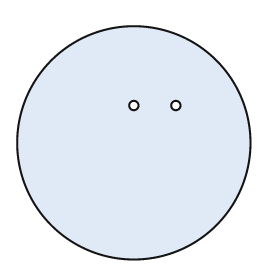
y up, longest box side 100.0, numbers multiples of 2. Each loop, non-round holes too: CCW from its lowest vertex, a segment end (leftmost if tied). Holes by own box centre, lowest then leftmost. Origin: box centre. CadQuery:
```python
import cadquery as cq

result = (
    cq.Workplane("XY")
    .moveTo(0.0, 0.0)
    .circle(50.0)
    .moveTo(0.0, 16.0)
    .circle(2.0)
    .moveTo(18.0, 16.0)
    .circle(2.0)
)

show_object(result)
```